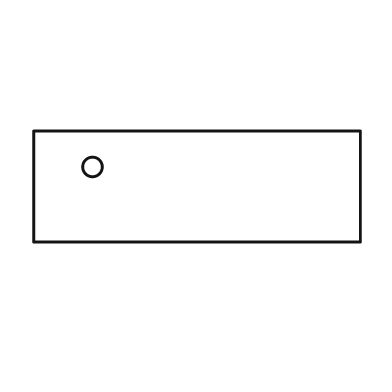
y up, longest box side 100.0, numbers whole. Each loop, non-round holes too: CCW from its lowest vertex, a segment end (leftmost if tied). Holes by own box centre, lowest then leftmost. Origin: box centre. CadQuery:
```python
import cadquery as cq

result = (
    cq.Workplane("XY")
    .moveTo(-50.0, -17.0)
    .lineTo(50.0, -17.0)
    .lineTo(50.0, 17.0)
    .lineTo(-50.0, 17.0)
    .close()
    .moveTo(-32.0, 6.0)
    .circle(3.0)
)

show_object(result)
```